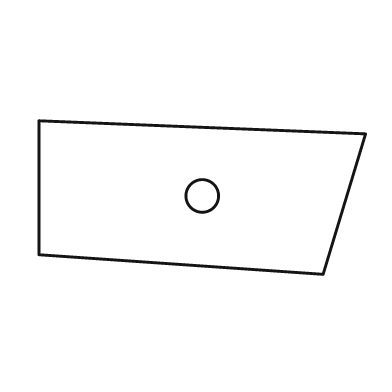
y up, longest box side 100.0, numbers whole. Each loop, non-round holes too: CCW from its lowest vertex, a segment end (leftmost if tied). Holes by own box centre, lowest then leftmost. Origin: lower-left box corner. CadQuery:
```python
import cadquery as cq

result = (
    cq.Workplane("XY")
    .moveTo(87.0, 0.0)
    .lineTo(100.0, 43.0)
    .lineTo(0.0, 47.0)
    .lineTo(0.0, 6.0)
    .close()
    .moveTo(50.0, 24.0)
    .circle(5.0)
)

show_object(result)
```